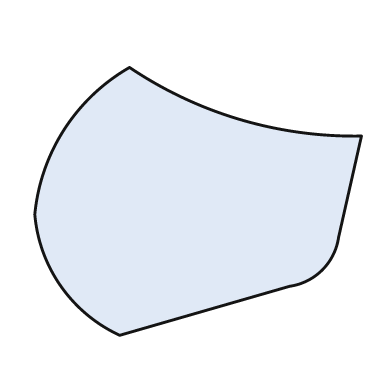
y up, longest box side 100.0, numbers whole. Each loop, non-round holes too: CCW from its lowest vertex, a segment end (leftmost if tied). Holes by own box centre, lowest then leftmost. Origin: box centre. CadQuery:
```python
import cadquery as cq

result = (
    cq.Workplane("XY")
    .moveTo(-24.0, -41.0)
    .lineTo(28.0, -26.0)
    .threePointArc((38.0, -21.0), (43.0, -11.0))
    .lineTo(50.0, 20.0)
    .threePointArc((13.0, 25.0), (-21.0, 41.0))
    .threePointArc((-41.0, 22.0), (-50.0, -4.0))
    .threePointArc((-42.0, -26.0), (-24.0, -41.0))
    .close()
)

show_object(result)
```